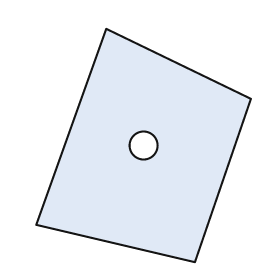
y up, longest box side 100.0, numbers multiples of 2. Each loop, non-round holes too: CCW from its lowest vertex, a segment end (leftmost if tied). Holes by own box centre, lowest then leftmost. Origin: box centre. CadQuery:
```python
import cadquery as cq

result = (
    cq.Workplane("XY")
    .moveTo(22.0, -50.0)
    .lineTo(46.0, 20.0)
    .lineTo(-16.0, 50.0)
    .lineTo(-46.0, -34.0)
    .close()
    .moveTo(0.0, 0.0)
    .circle(6.0)
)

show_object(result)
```